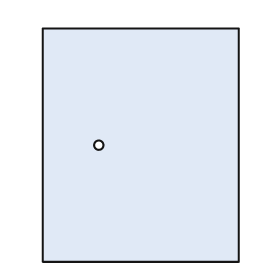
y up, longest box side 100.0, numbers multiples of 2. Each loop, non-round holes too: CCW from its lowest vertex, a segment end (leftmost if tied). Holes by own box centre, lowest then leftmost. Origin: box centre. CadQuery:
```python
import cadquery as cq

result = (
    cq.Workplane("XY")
    .moveTo(-42.0, -50.0)
    .lineTo(42.0, -50.0)
    .lineTo(42.0, 50.0)
    .lineTo(-42.0, 50.0)
    .close()
    .moveTo(-18.0, 0.0)
    .circle(2.0)
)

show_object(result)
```